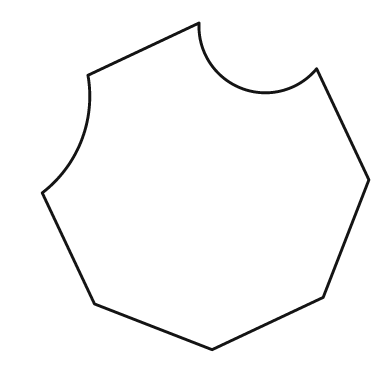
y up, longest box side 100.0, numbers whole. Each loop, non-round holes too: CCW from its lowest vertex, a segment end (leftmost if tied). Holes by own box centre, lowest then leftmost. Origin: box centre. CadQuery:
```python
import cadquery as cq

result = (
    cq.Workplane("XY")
    .moveTo(2.0, -50.0)
    .lineTo(36.0, -34.0)
    .lineTo(50.0, 2.0)
    .lineTo(34.0, 36.0)
    .threePointArc((11.0, 30.0), (-2.0, 50.0))
    .lineTo(-36.0, 34.0)
    .threePointArc((-38.0, 14.0), (-50.0, -2.0))
    .lineTo(-34.0, -36.0)
    .close()
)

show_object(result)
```